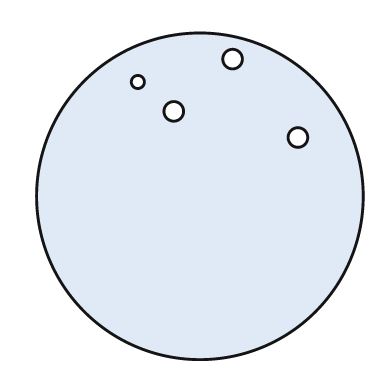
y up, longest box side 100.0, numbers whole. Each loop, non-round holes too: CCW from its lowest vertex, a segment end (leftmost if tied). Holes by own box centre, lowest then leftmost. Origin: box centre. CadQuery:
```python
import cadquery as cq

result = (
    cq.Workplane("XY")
    .moveTo(0.0, 0.0)
    .circle(50.0)
    .moveTo(30.0, 18.0)
    .circle(3.0)
    .moveTo(-8.0, 26.0)
    .circle(3.0)
    .moveTo(-19.0, 35.0)
    .circle(2.0)
    .moveTo(10.0, 42.0)
    .circle(3.0)
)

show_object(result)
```